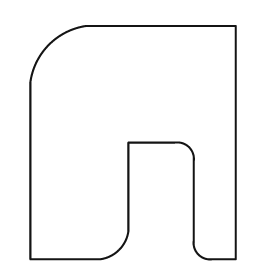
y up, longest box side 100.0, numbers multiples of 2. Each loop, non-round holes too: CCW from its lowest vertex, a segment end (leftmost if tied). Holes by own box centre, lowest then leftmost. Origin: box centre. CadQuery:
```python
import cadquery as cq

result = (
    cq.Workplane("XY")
    .moveTo(-44.0, -50.0)
    .lineTo(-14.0, -50.0)
    .threePointArc((-6.0, -46.0), (-2.0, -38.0))
    .lineTo(-2.0, 0.0)
    .lineTo(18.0, 0.0)
    .threePointArc((24.0, -2.0), (26.0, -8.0))
    .lineTo(26.0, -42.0)
    .threePointArc((28.0, -48.0), (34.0, -50.0))
    .lineTo(44.0, -50.0)
    .lineTo(44.0, 50.0)
    .lineTo(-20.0, 50.0)
    .threePointArc((-36.0, 42.0), (-44.0, 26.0))
    .close()
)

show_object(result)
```